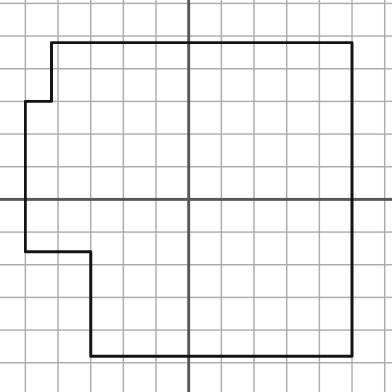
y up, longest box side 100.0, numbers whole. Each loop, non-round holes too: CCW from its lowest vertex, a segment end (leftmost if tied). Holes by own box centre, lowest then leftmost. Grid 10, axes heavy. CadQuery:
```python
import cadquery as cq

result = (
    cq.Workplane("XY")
    .moveTo(-30.0, -48.0)
    .lineTo(50.0, -48.0)
    .lineTo(50.0, 48.0)
    .lineTo(-42.0, 48.0)
    .lineTo(-42.0, 30.0)
    .lineTo(-50.0, 30.0)
    .lineTo(-50.0, -16.0)
    .lineTo(-30.0, -16.0)
    .close()
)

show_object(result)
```